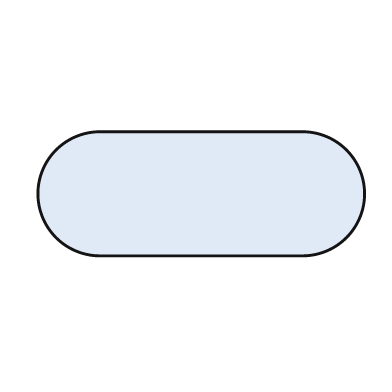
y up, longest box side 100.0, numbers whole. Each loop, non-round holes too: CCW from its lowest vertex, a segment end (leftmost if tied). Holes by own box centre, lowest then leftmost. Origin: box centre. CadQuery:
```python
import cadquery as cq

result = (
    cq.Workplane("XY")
    .moveTo(-31.0, -19.0)
    .lineTo(31.0, -19.0)
    .threePointArc((50.0, 0.0), (31.0, 19.0))
    .lineTo(-31.0, 19.0)
    .threePointArc((-50.0, 0.0), (-31.0, -19.0))
    .close()
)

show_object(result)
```